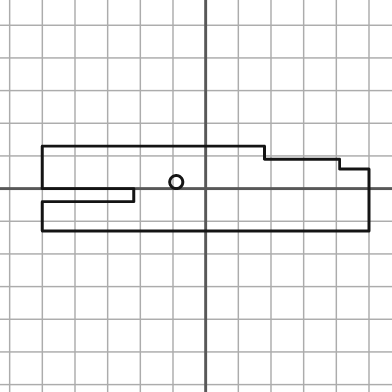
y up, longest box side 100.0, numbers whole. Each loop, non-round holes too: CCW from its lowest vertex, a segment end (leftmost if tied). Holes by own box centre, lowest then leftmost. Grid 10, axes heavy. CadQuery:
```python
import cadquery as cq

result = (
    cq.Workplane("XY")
    .moveTo(-50.0, -13.0)
    .lineTo(50.0, -13.0)
    .lineTo(50.0, 6.0)
    .lineTo(41.0, 6.0)
    .lineTo(41.0, 9.0)
    .lineTo(18.0, 9.0)
    .lineTo(18.0, 13.0)
    .lineTo(-50.0, 13.0)
    .lineTo(-50.0, 0.0)
    .lineTo(-22.0, 0.0)
    .lineTo(-22.0, -4.0)
    .lineTo(-50.0, -4.0)
    .close()
    .moveTo(-9.0, 2.0)
    .circle(2.0)
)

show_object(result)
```